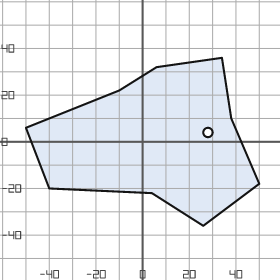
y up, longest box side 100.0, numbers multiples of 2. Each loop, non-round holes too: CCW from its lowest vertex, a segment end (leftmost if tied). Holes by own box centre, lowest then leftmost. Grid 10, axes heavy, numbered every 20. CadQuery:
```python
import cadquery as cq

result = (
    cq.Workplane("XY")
    .moveTo(26.0, -36.0)
    .lineTo(50.0, -18.0)
    .lineTo(38.0, 10.0)
    .lineTo(34.0, 36.0)
    .lineTo(6.0, 32.0)
    .lineTo(-10.0, 22.0)
    .lineTo(-50.0, 6.0)
    .lineTo(-40.0, -20.0)
    .lineTo(4.0, -22.0)
    .close()
    .moveTo(28.0, 4.0)
    .circle(2.0)
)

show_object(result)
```